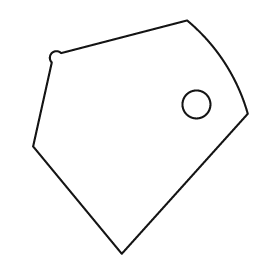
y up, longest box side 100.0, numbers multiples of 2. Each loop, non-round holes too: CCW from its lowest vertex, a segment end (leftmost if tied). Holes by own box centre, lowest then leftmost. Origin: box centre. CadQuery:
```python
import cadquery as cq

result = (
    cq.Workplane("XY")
    .moveTo(-8.0, -50.0)
    .lineTo(46.0, 10.0)
    .threePointArc((36.0, 32.0), (20.0, 50.0))
    .lineTo(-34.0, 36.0)
    .threePointArc((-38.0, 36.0), (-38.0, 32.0))
    .lineTo(-46.0, -4.0)
    .close()
    .moveTo(24.0, 14.0)
    .circle(6.0)
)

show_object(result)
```